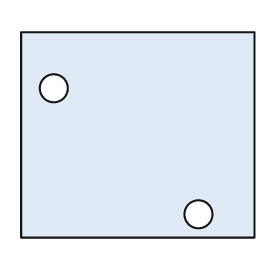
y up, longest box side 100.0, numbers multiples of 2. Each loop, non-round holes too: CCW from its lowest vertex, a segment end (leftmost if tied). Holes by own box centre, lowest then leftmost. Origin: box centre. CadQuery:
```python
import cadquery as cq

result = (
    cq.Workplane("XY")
    .moveTo(-50.0, -44.0)
    .lineTo(50.0, -44.0)
    .lineTo(50.0, 44.0)
    .lineTo(-50.0, 44.0)
    .close()
    .moveTo(26.0, -34.0)
    .circle(6.0)
    .moveTo(-36.0, 20.0)
    .circle(6.0)
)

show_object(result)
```